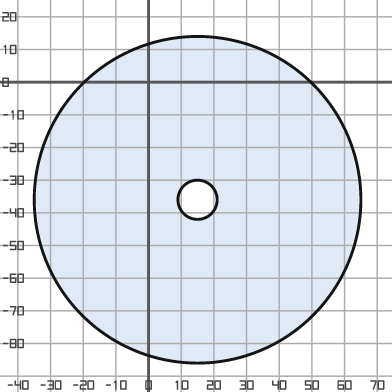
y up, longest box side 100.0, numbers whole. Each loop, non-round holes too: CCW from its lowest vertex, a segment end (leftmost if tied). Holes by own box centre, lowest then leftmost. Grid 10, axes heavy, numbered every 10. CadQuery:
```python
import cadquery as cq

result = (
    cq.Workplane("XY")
    .moveTo(15.0, -36.0)
    .circle(50.0)
    .moveTo(15.0, -36.0)
    .circle(6.0)
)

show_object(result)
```